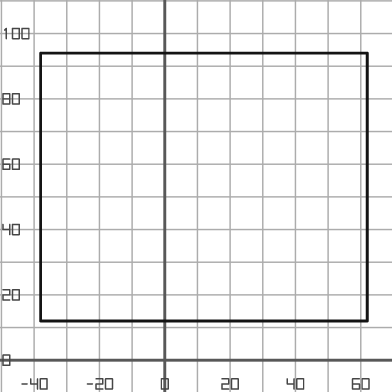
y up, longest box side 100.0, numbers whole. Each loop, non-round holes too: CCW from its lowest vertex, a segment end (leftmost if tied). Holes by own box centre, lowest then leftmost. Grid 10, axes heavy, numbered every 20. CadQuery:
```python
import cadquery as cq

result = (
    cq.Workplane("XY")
    .moveTo(-38.0, 12.0)
    .lineTo(62.0, 12.0)
    .lineTo(62.0, 94.0)
    .lineTo(-38.0, 94.0)
    .close()
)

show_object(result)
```